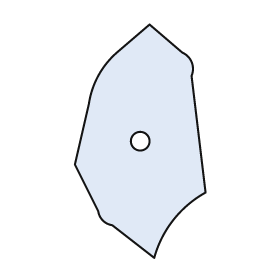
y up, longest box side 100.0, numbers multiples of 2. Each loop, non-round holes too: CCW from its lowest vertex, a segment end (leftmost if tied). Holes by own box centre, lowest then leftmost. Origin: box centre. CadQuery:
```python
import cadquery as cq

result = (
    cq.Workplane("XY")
    .moveTo(6.0, -50.0)
    .threePointArc((14.0, -34.0), (28.0, -22.0))
    .lineTo(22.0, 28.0)
    .threePointArc((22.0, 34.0), (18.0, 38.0))
    .lineTo(4.0, 50.0)
    .lineTo(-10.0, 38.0)
    .threePointArc((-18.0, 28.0), (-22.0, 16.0))
    .lineTo(-28.0, -10.0)
    .lineTo(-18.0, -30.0)
    .threePointArc((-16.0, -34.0), (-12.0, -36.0))
    .close()
    .moveTo(0.0, 0.0)
    .circle(4.0)
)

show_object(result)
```